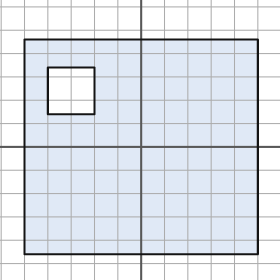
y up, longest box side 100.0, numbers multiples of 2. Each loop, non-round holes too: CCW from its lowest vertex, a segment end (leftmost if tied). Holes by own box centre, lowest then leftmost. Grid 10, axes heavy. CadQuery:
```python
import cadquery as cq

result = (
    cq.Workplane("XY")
    .moveTo(-50.0, -46.0)
    .lineTo(50.0, -46.0)
    .lineTo(50.0, 46.0)
    .lineTo(-50.0, 46.0)
    .close()
    .moveTo(-40.0, 14.0)
    .lineTo(-20.0, 14.0)
    .lineTo(-20.0, 34.0)
    .lineTo(-40.0, 34.0)
    .close()
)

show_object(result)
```